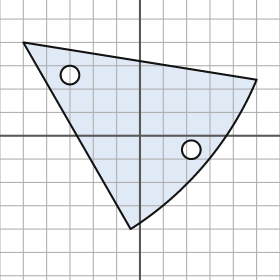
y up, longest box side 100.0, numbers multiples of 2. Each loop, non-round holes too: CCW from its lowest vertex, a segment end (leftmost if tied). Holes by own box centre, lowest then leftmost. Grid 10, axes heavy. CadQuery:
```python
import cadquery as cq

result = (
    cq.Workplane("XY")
    .moveTo(-4.0, -40.0)
    .threePointArc((28.0, -12.0), (50.0, 24.0))
    .lineTo(-50.0, 40.0)
    .close()
    .moveTo(22.0, -6.0)
    .circle(4.0)
    .moveTo(-30.0, 26.0)
    .circle(4.0)
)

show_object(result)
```